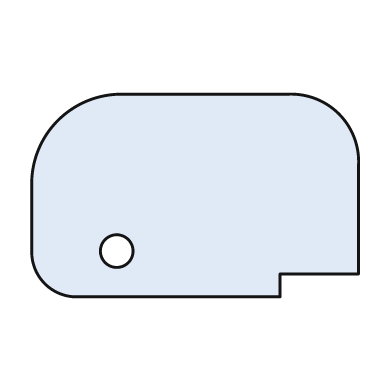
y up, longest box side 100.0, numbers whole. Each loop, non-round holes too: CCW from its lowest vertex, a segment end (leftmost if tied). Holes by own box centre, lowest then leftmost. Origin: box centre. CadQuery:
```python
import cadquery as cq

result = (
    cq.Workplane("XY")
    .moveTo(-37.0, -31.0)
    .lineTo(26.0, -31.0)
    .lineTo(26.0, -24.0)
    .lineTo(50.0, -24.0)
    .lineTo(50.0, 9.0)
    .threePointArc((44.0, 25.0), (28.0, 31.0))
    .lineTo(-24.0, 31.0)
    .threePointArc((-42.0, 23.0), (-50.0, 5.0))
    .lineTo(-50.0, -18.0)
    .threePointArc((-46.0, -27.0), (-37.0, -31.0))
    .close()
    .moveTo(-24.0, -17.0)
    .circle(5.0)
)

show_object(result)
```